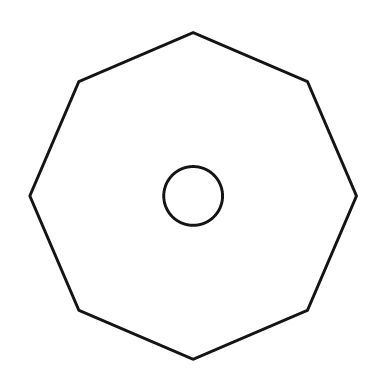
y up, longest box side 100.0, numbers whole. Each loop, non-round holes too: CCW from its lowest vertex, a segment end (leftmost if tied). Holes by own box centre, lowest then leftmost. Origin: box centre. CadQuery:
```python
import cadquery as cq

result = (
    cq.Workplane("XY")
    .moveTo(0.0, -50.0)
    .lineTo(35.0, -35.0)
    .lineTo(50.0, 0.0)
    .lineTo(35.0, 35.0)
    .lineTo(0.0, 50.0)
    .lineTo(-35.0, 35.0)
    .lineTo(-50.0, 0.0)
    .lineTo(-35.0, -35.0)
    .close()
    .moveTo(0.0, 0.0)
    .circle(9.0)
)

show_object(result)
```